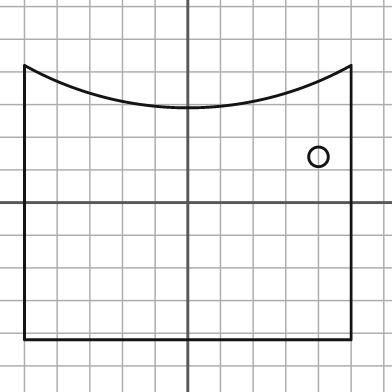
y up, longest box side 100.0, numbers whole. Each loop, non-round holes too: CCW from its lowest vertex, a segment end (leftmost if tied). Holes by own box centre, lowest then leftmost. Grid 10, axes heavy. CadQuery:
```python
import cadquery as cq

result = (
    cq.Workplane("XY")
    .moveTo(-50.0, -42.0)
    .lineTo(50.0, -42.0)
    .lineTo(50.0, 42.0)
    .threePointArc((0.0, 29.0), (-50.0, 42.0))
    .close()
    .moveTo(40.0, 14.0)
    .circle(3.0)
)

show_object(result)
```